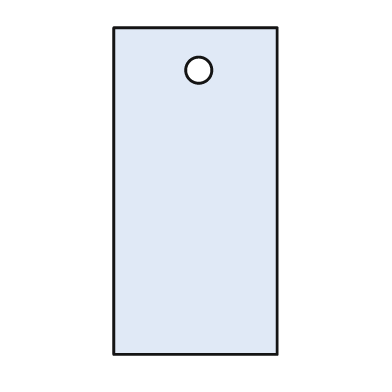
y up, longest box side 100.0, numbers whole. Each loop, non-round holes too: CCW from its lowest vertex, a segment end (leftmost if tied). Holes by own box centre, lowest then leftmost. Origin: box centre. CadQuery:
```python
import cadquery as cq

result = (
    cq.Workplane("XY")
    .moveTo(-25.0, -50.0)
    .lineTo(25.0, -50.0)
    .lineTo(25.0, 50.0)
    .lineTo(-25.0, 50.0)
    .close()
    .moveTo(1.0, 37.0)
    .circle(4.0)
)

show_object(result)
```